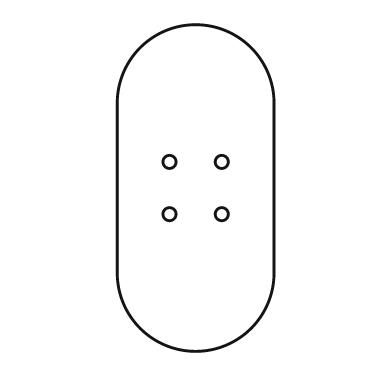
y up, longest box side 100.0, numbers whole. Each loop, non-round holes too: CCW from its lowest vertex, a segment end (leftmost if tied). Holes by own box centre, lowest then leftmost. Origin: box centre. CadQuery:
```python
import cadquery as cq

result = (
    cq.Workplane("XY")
    .moveTo(-24.0, -26.0)
    .threePointArc((0.0, -50.0), (24.0, -26.0))
    .lineTo(24.0, 26.0)
    .threePointArc((0.0, 50.0), (-24.0, 26.0))
    .close()
    .moveTo(-8.0, -8.0)
    .circle(2.0)
    .moveTo(8.0, -8.0)
    .circle(2.0)
    .moveTo(-8.0, 8.0)
    .circle(2.0)
    .moveTo(8.0, 8.0)
    .circle(2.0)
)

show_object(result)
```